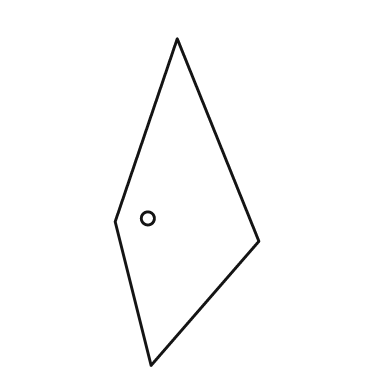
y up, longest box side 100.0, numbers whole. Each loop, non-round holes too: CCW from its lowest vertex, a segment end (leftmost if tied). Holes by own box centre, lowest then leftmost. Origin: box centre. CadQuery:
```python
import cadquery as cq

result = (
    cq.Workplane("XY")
    .moveTo(-11.0, -50.0)
    .lineTo(22.0, -12.0)
    .lineTo(-3.0, 50.0)
    .lineTo(-22.0, -6.0)
    .close()
    .moveTo(-12.0, -5.0)
    .circle(2.0)
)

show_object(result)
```